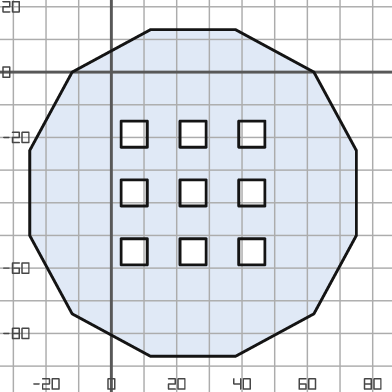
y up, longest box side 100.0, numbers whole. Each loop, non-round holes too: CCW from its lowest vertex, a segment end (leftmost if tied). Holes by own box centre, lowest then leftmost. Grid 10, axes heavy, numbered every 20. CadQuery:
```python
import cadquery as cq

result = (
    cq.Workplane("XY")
    .moveTo(12.0, -87.0)
    .lineTo(38.0, -87.0)
    .lineTo(62.0, -74.0)
    .lineTo(75.0, -50.0)
    .lineTo(75.0, -24.0)
    .lineTo(62.0, 0.0)
    .lineTo(38.0, 13.0)
    .lineTo(12.0, 13.0)
    .lineTo(-12.0, 0.0)
    .lineTo(-25.0, -24.0)
    .lineTo(-25.0, -50.0)
    .lineTo(-12.0, -74.0)
    .close()
    .moveTo(3.0, -59.0)
    .lineTo(11.0, -59.0)
    .lineTo(11.0, -51.0)
    .lineTo(3.0, -51.0)
    .close()
    .moveTo(21.0, -59.0)
    .lineTo(29.0, -59.0)
    .lineTo(29.0, -51.0)
    .lineTo(21.0, -51.0)
    .close()
    .moveTo(39.0, -59.0)
    .lineTo(47.0, -59.0)
    .lineTo(47.0, -51.0)
    .lineTo(39.0, -51.0)
    .close()
    .moveTo(3.0, -41.0)
    .lineTo(11.0, -41.0)
    .lineTo(11.0, -33.0)
    .lineTo(3.0, -33.0)
    .close()
    .moveTo(21.0, -41.0)
    .lineTo(29.0, -41.0)
    .lineTo(29.0, -33.0)
    .lineTo(21.0, -33.0)
    .close()
    .moveTo(39.0, -41.0)
    .lineTo(47.0, -41.0)
    .lineTo(47.0, -33.0)
    .lineTo(39.0, -33.0)
    .close()
    .moveTo(3.0, -23.0)
    .lineTo(11.0, -23.0)
    .lineTo(11.0, -15.0)
    .lineTo(3.0, -15.0)
    .close()
    .moveTo(21.0, -23.0)
    .lineTo(29.0, -23.0)
    .lineTo(29.0, -15.0)
    .lineTo(21.0, -15.0)
    .close()
    .moveTo(39.0, -23.0)
    .lineTo(47.0, -23.0)
    .lineTo(47.0, -15.0)
    .lineTo(39.0, -15.0)
    .close()
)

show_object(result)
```